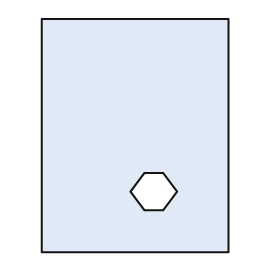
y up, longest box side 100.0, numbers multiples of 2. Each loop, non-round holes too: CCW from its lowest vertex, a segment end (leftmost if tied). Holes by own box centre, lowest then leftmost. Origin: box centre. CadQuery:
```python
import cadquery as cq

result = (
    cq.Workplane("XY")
    .moveTo(-40.0, -50.0)
    .lineTo(40.0, -50.0)
    .lineTo(40.0, 50.0)
    .lineTo(-40.0, 50.0)
    .close()
    .moveTo(4.0, -32.0)
    .lineTo(12.0, -32.0)
    .lineTo(18.0, -24.0)
    .lineTo(12.0, -16.0)
    .lineTo(4.0, -16.0)
    .lineTo(-2.0, -24.0)
    .close()
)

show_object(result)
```